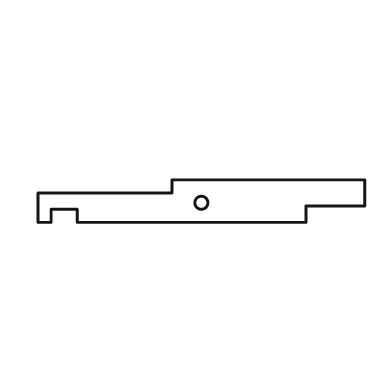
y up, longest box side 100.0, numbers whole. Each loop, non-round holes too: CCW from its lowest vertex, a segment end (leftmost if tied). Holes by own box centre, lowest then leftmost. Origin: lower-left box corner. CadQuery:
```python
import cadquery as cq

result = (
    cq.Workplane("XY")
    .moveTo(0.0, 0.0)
    .lineTo(4.0, 0.0)
    .lineTo(4.0, 4.0)
    .lineTo(12.0, 4.0)
    .lineTo(12.0, 0.0)
    .lineTo(82.0, 0.0)
    .lineTo(82.0, 5.0)
    .lineTo(100.0, 5.0)
    .lineTo(100.0, 13.0)
    .lineTo(41.0, 13.0)
    .lineTo(41.0, 9.0)
    .lineTo(0.0, 9.0)
    .close()
    .moveTo(50.0, 6.0)
    .circle(2.0)
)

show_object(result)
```